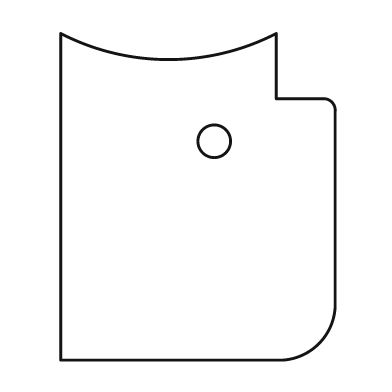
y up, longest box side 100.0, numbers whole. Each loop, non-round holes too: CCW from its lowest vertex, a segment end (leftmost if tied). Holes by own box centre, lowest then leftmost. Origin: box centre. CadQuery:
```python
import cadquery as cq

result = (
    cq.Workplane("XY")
    .moveTo(-42.0, -50.0)
    .lineTo(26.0, -50.0)
    .threePointArc((37.0, -45.0), (42.0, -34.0))
    .lineTo(42.0, 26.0)
    .threePointArc((41.0, 29.0), (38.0, 30.0))
    .lineTo(24.0, 30.0)
    .lineTo(24.0, 50.0)
    .threePointArc((-9.0, 42.0), (-42.0, 50.0))
    .close()
    .moveTo(5.0, 17.0)
    .circle(5.0)
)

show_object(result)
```